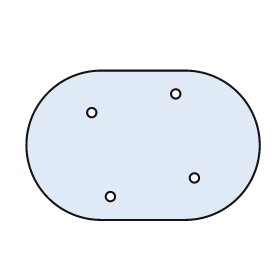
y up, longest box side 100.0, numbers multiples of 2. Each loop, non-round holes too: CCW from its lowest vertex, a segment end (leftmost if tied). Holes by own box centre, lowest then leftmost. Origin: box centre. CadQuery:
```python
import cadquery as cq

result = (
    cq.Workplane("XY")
    .moveTo(-18.0, -32.0)
    .lineTo(18.0, -32.0)
    .threePointArc((50.0, 0.0), (18.0, 32.0))
    .lineTo(-18.0, 32.0)
    .threePointArc((-50.0, 0.0), (-18.0, -32.0))
    .close()
    .moveTo(-14.0, -22.0)
    .circle(2.0)
    .moveTo(22.0, -14.0)
    .circle(2.0)
    .moveTo(-22.0, 14.0)
    .circle(2.0)
    .moveTo(14.0, 22.0)
    .circle(2.0)
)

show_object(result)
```